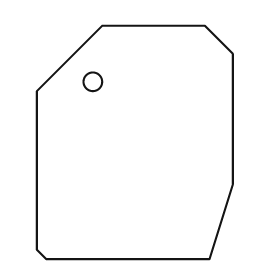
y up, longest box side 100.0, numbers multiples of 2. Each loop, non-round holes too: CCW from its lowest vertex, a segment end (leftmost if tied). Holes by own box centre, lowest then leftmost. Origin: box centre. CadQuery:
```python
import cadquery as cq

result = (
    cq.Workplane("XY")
    .moveTo(-38.0, -50.0)
    .lineTo(32.0, -50.0)
    .lineTo(42.0, -18.0)
    .lineTo(42.0, 38.0)
    .lineTo(30.0, 50.0)
    .lineTo(-14.0, 50.0)
    .lineTo(-42.0, 22.0)
    .lineTo(-42.0, -46.0)
    .close()
    .moveTo(-18.0, 26.0)
    .circle(4.0)
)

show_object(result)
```